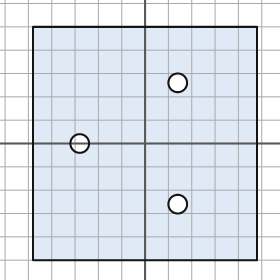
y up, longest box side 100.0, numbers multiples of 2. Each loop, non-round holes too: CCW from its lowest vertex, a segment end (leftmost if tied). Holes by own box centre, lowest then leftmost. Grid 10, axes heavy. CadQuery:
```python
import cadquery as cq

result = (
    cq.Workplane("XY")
    .moveTo(-48.0, -50.0)
    .lineTo(48.0, -50.0)
    .lineTo(48.0, 50.0)
    .lineTo(-48.0, 50.0)
    .close()
    .moveTo(14.0, -26.0)
    .circle(4.0)
    .moveTo(-28.0, 0.0)
    .circle(4.0)
    .moveTo(14.0, 26.0)
    .circle(4.0)
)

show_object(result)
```